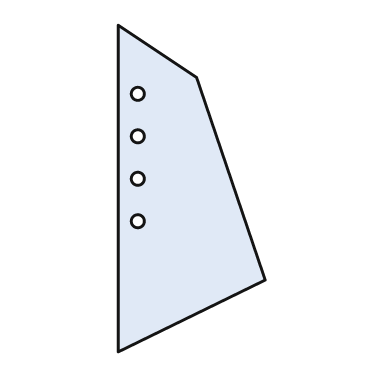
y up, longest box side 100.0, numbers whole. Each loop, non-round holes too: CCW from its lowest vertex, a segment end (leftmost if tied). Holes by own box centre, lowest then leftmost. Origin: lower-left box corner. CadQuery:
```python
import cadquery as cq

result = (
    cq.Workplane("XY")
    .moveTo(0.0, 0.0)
    .lineTo(45.0, 22.0)
    .lineTo(24.0, 84.0)
    .lineTo(0.0, 100.0)
    .close()
    .moveTo(6.0, 40.0)
    .circle(2.0)
    .moveTo(6.0, 53.0)
    .circle(2.0)
    .moveTo(6.0, 66.0)
    .circle(2.0)
    .moveTo(6.0, 79.0)
    .circle(2.0)
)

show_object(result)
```